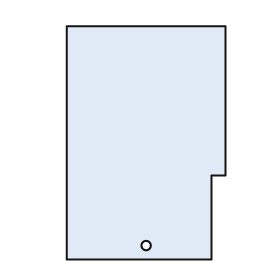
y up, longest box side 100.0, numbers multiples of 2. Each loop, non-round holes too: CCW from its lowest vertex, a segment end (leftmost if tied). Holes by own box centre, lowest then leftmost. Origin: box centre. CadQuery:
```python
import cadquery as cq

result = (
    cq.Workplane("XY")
    .moveTo(-34.0, -50.0)
    .lineTo(28.0, -50.0)
    .lineTo(28.0, -14.0)
    .lineTo(34.0, -14.0)
    .lineTo(34.0, 50.0)
    .lineTo(-34.0, 50.0)
    .close()
    .moveTo(0.0, -44.0)
    .circle(2.0)
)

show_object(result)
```